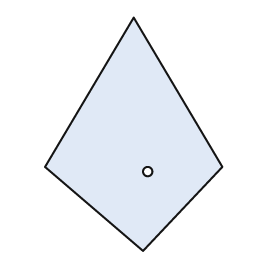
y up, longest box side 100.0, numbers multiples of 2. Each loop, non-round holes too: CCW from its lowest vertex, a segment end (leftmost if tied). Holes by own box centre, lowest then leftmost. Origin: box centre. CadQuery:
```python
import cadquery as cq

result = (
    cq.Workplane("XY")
    .moveTo(4.0, -50.0)
    .lineTo(38.0, -14.0)
    .lineTo(0.0, 50.0)
    .lineTo(-38.0, -14.0)
    .close()
    .moveTo(6.0, -16.0)
    .circle(2.0)
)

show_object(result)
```